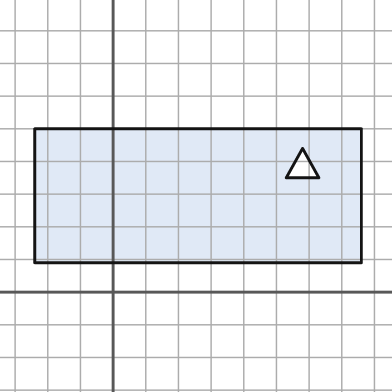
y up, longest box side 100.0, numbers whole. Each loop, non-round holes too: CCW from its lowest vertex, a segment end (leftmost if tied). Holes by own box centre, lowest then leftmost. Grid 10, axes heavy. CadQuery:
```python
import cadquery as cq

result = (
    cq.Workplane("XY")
    .moveTo(-24.0, 9.0)
    .lineTo(76.0, 9.0)
    .lineTo(76.0, 50.0)
    .lineTo(-24.0, 50.0)
    .close()
    .moveTo(53.0, 35.0)
    .lineTo(63.0, 35.0)
    .lineTo(58.0, 44.0)
    .close()
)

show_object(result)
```